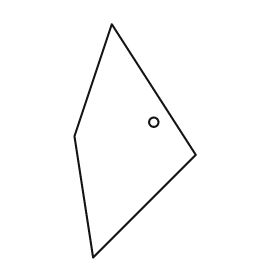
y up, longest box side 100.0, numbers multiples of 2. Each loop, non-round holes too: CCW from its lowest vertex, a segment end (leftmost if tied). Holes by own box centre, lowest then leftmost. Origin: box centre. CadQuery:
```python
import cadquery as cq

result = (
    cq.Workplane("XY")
    .moveTo(-18.0, -50.0)
    .lineTo(26.0, -6.0)
    .lineTo(-10.0, 50.0)
    .lineTo(-26.0, 2.0)
    .close()
    .moveTo(8.0, 8.0)
    .circle(2.0)
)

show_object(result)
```